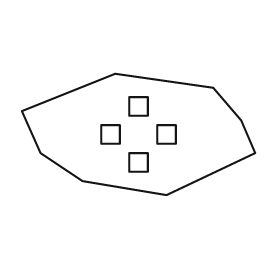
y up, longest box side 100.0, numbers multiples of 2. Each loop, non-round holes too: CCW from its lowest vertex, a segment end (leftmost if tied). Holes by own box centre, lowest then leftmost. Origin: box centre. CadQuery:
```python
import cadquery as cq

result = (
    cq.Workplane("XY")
    .moveTo(12.0, -26.0)
    .lineTo(50.0, -8.0)
    .lineTo(44.0, 6.0)
    .lineTo(32.0, 20.0)
    .lineTo(-10.0, 26.0)
    .lineTo(-50.0, 10.0)
    .lineTo(-42.0, -8.0)
    .lineTo(-24.0, -20.0)
    .close()
    .moveTo(-4.0, -16.0)
    .lineTo(4.0, -16.0)
    .lineTo(4.0, -8.0)
    .lineTo(-4.0, -8.0)
    .close()
    .moveTo(-16.0, -4.0)
    .lineTo(-8.0, -4.0)
    .lineTo(-8.0, 4.0)
    .lineTo(-16.0, 4.0)
    .close()
    .moveTo(8.0, -4.0)
    .lineTo(16.0, -4.0)
    .lineTo(16.0, 4.0)
    .lineTo(8.0, 4.0)
    .close()
    .moveTo(-4.0, 8.0)
    .lineTo(4.0, 8.0)
    .lineTo(4.0, 16.0)
    .lineTo(-4.0, 16.0)
    .close()
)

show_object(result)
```